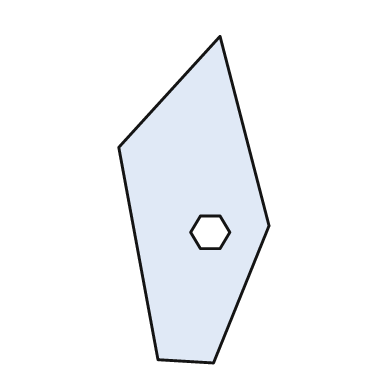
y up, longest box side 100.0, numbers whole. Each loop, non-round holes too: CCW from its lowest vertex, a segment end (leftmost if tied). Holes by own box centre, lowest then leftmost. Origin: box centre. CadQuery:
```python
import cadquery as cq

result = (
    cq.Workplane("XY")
    .moveTo(6.0, -50.0)
    .lineTo(23.0, -8.0)
    .lineTo(8.0, 50.0)
    .lineTo(-23.0, 16.0)
    .lineTo(-11.0, -49.0)
    .close()
    .moveTo(2.0, -15.0)
    .lineTo(8.0, -15.0)
    .lineTo(11.0, -10.0)
    .lineTo(8.0, -5.0)
    .lineTo(2.0, -5.0)
    .lineTo(-1.0, -10.0)
    .close()
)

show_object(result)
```